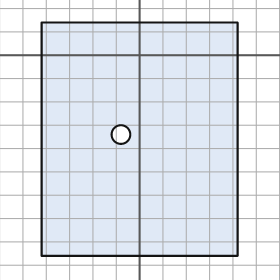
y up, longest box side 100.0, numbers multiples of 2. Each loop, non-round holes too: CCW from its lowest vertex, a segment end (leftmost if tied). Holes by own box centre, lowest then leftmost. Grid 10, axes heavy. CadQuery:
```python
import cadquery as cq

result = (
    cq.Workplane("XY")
    .moveTo(-42.0, -86.0)
    .lineTo(42.0, -86.0)
    .lineTo(42.0, 14.0)
    .lineTo(-42.0, 14.0)
    .close()
    .moveTo(-8.0, -34.0)
    .circle(4.0)
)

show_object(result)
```